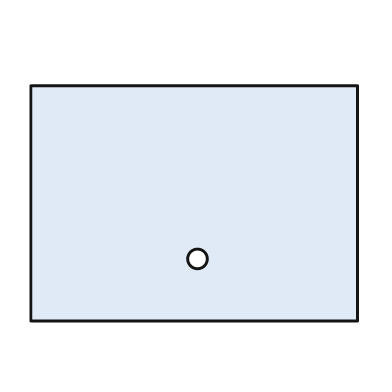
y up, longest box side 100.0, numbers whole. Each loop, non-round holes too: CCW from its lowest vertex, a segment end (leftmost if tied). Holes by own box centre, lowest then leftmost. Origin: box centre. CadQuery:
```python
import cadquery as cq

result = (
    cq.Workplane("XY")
    .moveTo(-50.0, -36.0)
    .lineTo(50.0, -36.0)
    .lineTo(50.0, 36.0)
    .lineTo(-50.0, 36.0)
    .close()
    .moveTo(1.0, -17.0)
    .circle(3.0)
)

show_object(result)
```